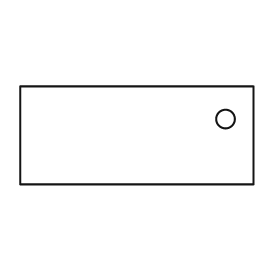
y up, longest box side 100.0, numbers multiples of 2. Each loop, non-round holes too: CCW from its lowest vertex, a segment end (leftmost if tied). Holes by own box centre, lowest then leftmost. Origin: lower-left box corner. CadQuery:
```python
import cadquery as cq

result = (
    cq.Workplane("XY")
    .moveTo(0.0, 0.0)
    .lineTo(100.0, 0.0)
    .lineTo(100.0, 42.0)
    .lineTo(0.0, 42.0)
    .close()
    .moveTo(88.0, 28.0)
    .circle(4.0)
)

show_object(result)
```